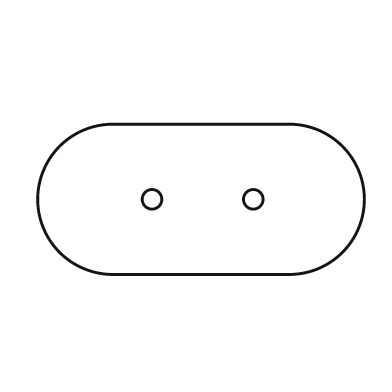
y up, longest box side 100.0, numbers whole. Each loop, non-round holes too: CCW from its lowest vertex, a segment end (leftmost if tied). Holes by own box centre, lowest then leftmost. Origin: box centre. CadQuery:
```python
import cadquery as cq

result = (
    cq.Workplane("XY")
    .moveTo(-27.0, -23.0)
    .lineTo(27.0, -23.0)
    .threePointArc((50.0, 0.0), (27.0, 23.0))
    .lineTo(-27.0, 23.0)
    .threePointArc((-50.0, 0.0), (-27.0, -23.0))
    .close()
    .moveTo(-15.0, 0.0)
    .circle(3.0)
    .moveTo(16.0, 0.0)
    .circle(3.0)
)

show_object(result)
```